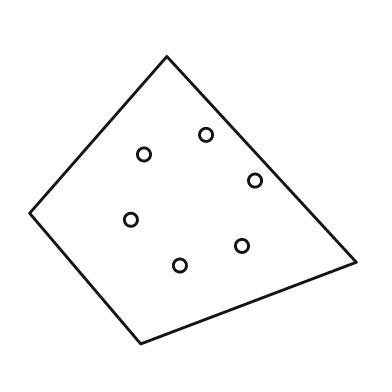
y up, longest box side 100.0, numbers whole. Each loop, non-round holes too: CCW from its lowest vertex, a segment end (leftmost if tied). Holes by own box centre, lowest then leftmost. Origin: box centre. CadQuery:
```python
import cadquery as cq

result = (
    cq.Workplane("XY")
    .moveTo(-16.0, -44.0)
    .lineTo(50.0, -19.0)
    .lineTo(-8.0, 44.0)
    .lineTo(-50.0, -4.0)
    .close()
    .moveTo(-4.0, -20.0)
    .circle(2.0)
    .moveTo(15.0, -14.0)
    .circle(2.0)
    .moveTo(-19.0, -6.0)
    .circle(2.0)
    .moveTo(19.0, 6.0)
    .circle(2.0)
    .moveTo(-15.0, 14.0)
    .circle(2.0)
    .moveTo(4.0, 20.0)
    .circle(2.0)
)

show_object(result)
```